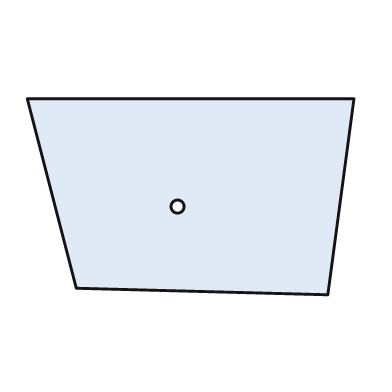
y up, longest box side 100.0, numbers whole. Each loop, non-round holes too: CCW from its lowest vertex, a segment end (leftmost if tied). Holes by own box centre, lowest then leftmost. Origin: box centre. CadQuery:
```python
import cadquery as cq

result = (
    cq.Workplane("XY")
    .moveTo(42.0, -30.0)
    .lineTo(50.0, 30.0)
    .lineTo(-50.0, 30.0)
    .lineTo(-35.0, -28.0)
    .close()
    .moveTo(-4.0, -3.0)
    .circle(2.0)
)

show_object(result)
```